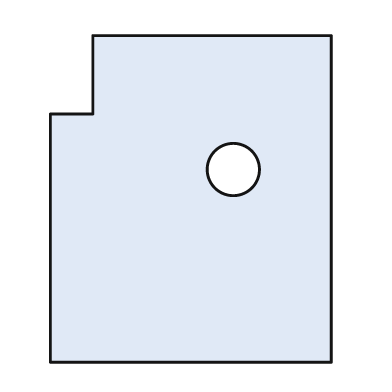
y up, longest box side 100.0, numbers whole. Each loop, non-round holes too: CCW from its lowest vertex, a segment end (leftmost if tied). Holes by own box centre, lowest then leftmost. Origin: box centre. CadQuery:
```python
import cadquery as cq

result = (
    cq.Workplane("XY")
    .moveTo(-43.0, -50.0)
    .lineTo(43.0, -50.0)
    .lineTo(43.0, 50.0)
    .lineTo(-30.0, 50.0)
    .lineTo(-30.0, 26.0)
    .lineTo(-43.0, 26.0)
    .close()
    .moveTo(13.0, 9.0)
    .circle(8.0)
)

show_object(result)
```